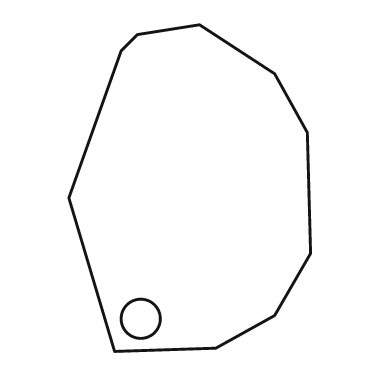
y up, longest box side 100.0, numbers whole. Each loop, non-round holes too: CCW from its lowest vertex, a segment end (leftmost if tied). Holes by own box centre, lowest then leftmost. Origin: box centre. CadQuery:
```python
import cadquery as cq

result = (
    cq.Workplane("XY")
    .moveTo(-23.0, -50.0)
    .lineTo(8.0, -49.0)
    .lineTo(26.0, -39.0)
    .lineTo(37.0, -20.0)
    .lineTo(36.0, 17.0)
    .lineTo(26.0, 35.0)
    .lineTo(3.0, 50.0)
    .lineTo(-16.0, 47.0)
    .lineTo(-21.0, 42.0)
    .lineTo(-37.0, -3.0)
    .close()
    .moveTo(-15.0, -40.0)
    .circle(6.0)
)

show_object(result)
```